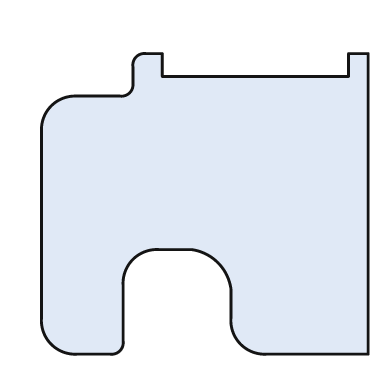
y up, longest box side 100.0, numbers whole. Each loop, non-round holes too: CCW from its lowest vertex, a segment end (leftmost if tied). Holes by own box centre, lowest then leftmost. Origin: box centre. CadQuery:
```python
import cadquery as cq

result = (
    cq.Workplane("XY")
    .moveTo(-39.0, -46.0)
    .lineTo(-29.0, -46.0)
    .threePointArc((-26.0, -45.0), (-25.0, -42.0))
    .lineTo(-25.0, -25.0)
    .threePointArc((-22.0, -17.0), (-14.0, -14.0))
    .lineTo(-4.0, -14.0)
    .threePointArc((4.0, -18.0), (8.0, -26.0))
    .lineTo(8.0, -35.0)
    .threePointArc((11.0, -43.0), (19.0, -46.0))
    .lineTo(50.0, -46.0)
    .lineTo(50.0, 46.0)
    .lineTo(44.0, 46.0)
    .lineTo(44.0, 39.0)
    .lineTo(-13.0, 39.0)
    .lineTo(-13.0, 46.0)
    .lineTo(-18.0, 46.0)
    .threePointArc((-21.0, 45.0), (-22.0, 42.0))
    .lineTo(-22.0, 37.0)
    .threePointArc((-23.0, 34.0), (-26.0, 33.0))
    .lineTo(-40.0, 33.0)
    .threePointArc((-47.0, 30.0), (-50.0, 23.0))
    .lineTo(-50.0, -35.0)
    .threePointArc((-47.0, -43.0), (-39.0, -46.0))
    .close()
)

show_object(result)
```